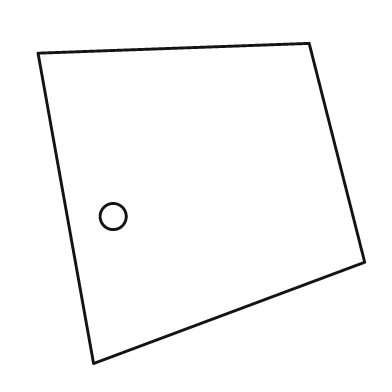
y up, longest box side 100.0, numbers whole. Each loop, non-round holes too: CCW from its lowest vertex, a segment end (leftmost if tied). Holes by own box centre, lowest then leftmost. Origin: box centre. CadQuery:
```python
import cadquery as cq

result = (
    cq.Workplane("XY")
    .moveTo(-33.0, -49.0)
    .lineTo(50.0, -18.0)
    .lineTo(33.0, 49.0)
    .lineTo(-50.0, 46.0)
    .close()
    .moveTo(-27.0, -4.0)
    .circle(4.0)
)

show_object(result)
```